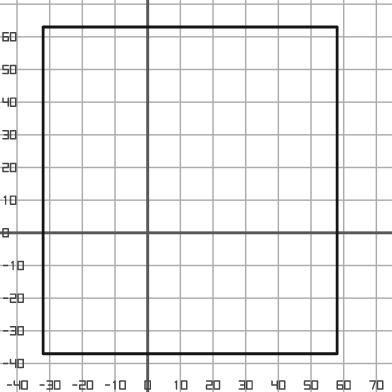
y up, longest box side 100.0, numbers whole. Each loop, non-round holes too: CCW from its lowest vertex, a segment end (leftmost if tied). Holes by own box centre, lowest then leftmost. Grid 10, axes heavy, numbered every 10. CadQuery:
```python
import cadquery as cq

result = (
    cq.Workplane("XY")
    .moveTo(-32.0, -37.0)
    .lineTo(58.0, -37.0)
    .lineTo(58.0, 63.0)
    .lineTo(-32.0, 63.0)
    .close()
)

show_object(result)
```